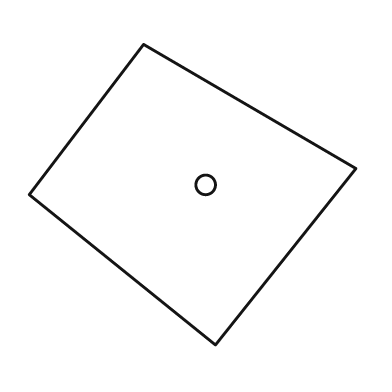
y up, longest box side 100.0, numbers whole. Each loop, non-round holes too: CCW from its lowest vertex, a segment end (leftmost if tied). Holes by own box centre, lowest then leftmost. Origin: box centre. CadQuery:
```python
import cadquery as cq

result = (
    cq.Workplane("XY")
    .moveTo(7.0, -46.0)
    .lineTo(50.0, 8.0)
    .lineTo(-15.0, 46.0)
    .lineTo(-50.0, 0.0)
    .close()
    .moveTo(4.0, 3.0)
    .circle(3.0)
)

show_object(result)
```